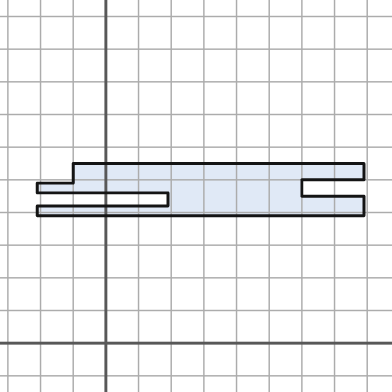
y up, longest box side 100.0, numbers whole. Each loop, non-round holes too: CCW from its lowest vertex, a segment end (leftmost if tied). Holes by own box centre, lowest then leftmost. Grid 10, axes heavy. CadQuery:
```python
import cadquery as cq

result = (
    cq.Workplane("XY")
    .moveTo(-21.0, 39.0)
    .lineTo(79.0, 39.0)
    .lineTo(79.0, 45.0)
    .lineTo(60.0, 45.0)
    .lineTo(60.0, 50.0)
    .lineTo(79.0, 50.0)
    .lineTo(79.0, 55.0)
    .lineTo(-10.0, 55.0)
    .lineTo(-10.0, 49.0)
    .lineTo(-21.0, 49.0)
    .lineTo(-21.0, 46.0)
    .lineTo(19.0, 46.0)
    .lineTo(19.0, 42.0)
    .lineTo(-21.0, 42.0)
    .close()
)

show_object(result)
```